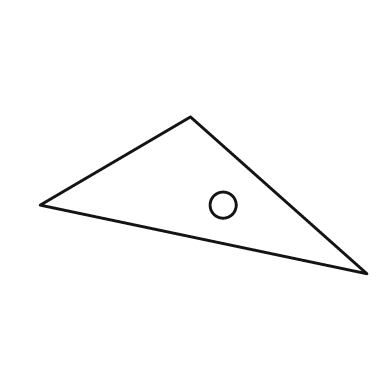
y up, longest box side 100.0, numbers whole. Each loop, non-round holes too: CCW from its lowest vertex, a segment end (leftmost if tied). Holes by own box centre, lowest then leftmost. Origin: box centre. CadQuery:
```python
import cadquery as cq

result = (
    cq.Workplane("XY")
    .moveTo(50.0, -24.0)
    .lineTo(-4.0, 24.0)
    .lineTo(-50.0, -3.0)
    .close()
    .moveTo(6.0, -3.0)
    .circle(4.0)
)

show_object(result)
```